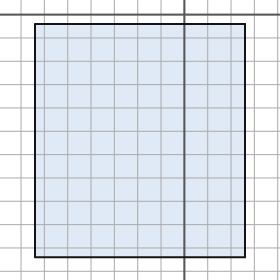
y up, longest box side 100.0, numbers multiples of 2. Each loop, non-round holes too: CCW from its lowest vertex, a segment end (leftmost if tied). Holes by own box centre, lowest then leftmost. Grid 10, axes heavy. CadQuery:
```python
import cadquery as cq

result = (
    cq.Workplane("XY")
    .moveTo(-64.0, -104.0)
    .lineTo(26.0, -104.0)
    .lineTo(26.0, -4.0)
    .lineTo(-64.0, -4.0)
    .close()
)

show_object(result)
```